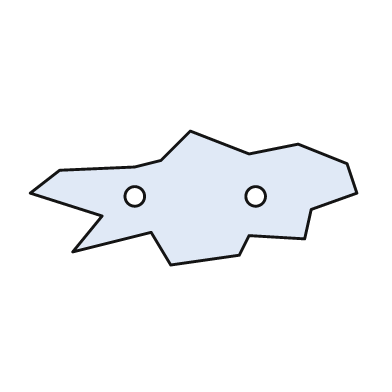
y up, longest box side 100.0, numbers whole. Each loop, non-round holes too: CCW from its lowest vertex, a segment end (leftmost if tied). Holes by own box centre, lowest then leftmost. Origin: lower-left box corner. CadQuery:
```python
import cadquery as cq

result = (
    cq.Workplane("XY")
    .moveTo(43.0, 0.0)
    .lineTo(64.0, 3.0)
    .lineTo(67.0, 9.0)
    .lineTo(84.0, 8.0)
    .lineTo(86.0, 17.0)
    .lineTo(100.0, 22.0)
    .lineTo(97.0, 31.0)
    .lineTo(82.0, 37.0)
    .lineTo(67.0, 34.0)
    .lineTo(49.0, 41.0)
    .lineTo(40.0, 32.0)
    .lineTo(32.0, 30.0)
    .lineTo(9.0, 29.0)
    .lineTo(0.0, 22.0)
    .lineTo(22.0, 15.0)
    .lineTo(13.0, 4.0)
    .lineTo(37.0, 10.0)
    .close()
    .moveTo(32.0, 21.0)
    .circle(3.0)
    .moveTo(69.0, 21.0)
    .circle(3.0)
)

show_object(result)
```